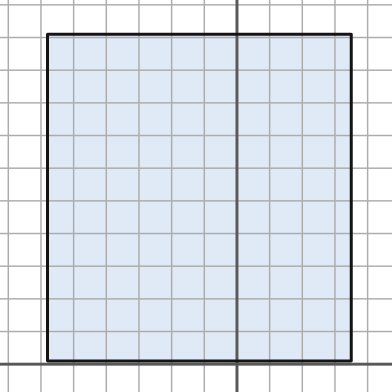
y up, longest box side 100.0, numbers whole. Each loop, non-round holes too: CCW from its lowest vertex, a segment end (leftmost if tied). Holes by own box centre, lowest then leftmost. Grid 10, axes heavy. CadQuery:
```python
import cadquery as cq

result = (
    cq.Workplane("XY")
    .moveTo(-58.0, 1.0)
    .lineTo(35.0, 1.0)
    .lineTo(35.0, 101.0)
    .lineTo(-58.0, 101.0)
    .close()
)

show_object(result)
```